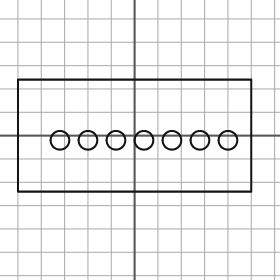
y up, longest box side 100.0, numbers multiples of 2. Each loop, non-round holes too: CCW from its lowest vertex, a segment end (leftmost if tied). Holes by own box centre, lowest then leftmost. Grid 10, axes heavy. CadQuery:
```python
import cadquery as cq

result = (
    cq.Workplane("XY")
    .moveTo(-50.0, -24.0)
    .lineTo(50.0, -24.0)
    .lineTo(50.0, 24.0)
    .lineTo(-50.0, 24.0)
    .close()
    .moveTo(-32.0, -2.0)
    .circle(4.0)
    .moveTo(-20.0, -2.0)
    .circle(4.0)
    .moveTo(-8.0, -2.0)
    .circle(4.0)
    .moveTo(4.0, -2.0)
    .circle(4.0)
    .moveTo(16.0, -2.0)
    .circle(4.0)
    .moveTo(28.0, -2.0)
    .circle(4.0)
    .moveTo(40.0, -2.0)
    .circle(4.0)
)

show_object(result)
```